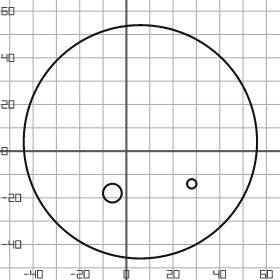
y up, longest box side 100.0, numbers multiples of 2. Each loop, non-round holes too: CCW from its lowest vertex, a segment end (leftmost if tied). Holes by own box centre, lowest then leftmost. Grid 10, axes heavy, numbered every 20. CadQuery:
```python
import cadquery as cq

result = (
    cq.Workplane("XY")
    .moveTo(6.0, 4.0)
    .circle(50.0)
    .moveTo(-6.0, -18.0)
    .circle(4.0)
    .moveTo(28.0, -14.0)
    .circle(2.0)
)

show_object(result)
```